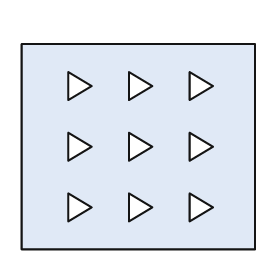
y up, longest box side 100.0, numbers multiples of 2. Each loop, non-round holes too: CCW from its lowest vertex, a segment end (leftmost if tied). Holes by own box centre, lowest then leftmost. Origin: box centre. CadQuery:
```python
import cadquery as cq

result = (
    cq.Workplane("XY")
    .moveTo(-50.0, -44.0)
    .lineTo(50.0, -44.0)
    .lineTo(50.0, 44.0)
    .lineTo(-50.0, 44.0)
    .close()
    .moveTo(-30.0, -32.0)
    .lineTo(-20.0, -26.0)
    .lineTo(-30.0, -20.0)
    .close()
    .moveTo(-4.0, -32.0)
    .lineTo(6.0, -26.0)
    .lineTo(-4.0, -20.0)
    .close()
    .moveTo(22.0, -32.0)
    .lineTo(32.0, -26.0)
    .lineTo(22.0, -20.0)
    .close()
    .moveTo(-30.0, -6.0)
    .lineTo(-20.0, 0.0)
    .lineTo(-30.0, 6.0)
    .close()
    .moveTo(-4.0, -6.0)
    .lineTo(6.0, 0.0)
    .lineTo(-4.0, 6.0)
    .close()
    .moveTo(22.0, -6.0)
    .lineTo(32.0, 0.0)
    .lineTo(22.0, 6.0)
    .close()
    .moveTo(-30.0, 20.0)
    .lineTo(-20.0, 26.0)
    .lineTo(-30.0, 32.0)
    .close()
    .moveTo(-4.0, 20.0)
    .lineTo(6.0, 26.0)
    .lineTo(-4.0, 32.0)
    .close()
    .moveTo(22.0, 20.0)
    .lineTo(32.0, 26.0)
    .lineTo(22.0, 32.0)
    .close()
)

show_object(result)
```